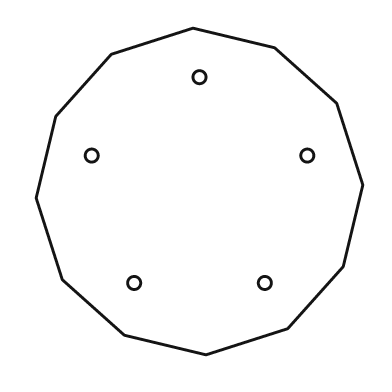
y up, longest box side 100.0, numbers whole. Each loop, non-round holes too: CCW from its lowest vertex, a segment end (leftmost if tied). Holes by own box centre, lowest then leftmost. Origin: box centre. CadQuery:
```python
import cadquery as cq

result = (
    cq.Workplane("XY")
    .moveTo(2.0, -50.0)
    .lineTo(27.0, -42.0)
    .lineTo(44.0, -23.0)
    .lineTo(50.0, 2.0)
    .lineTo(42.0, 27.0)
    .lineTo(23.0, 44.0)
    .lineTo(-2.0, 50.0)
    .lineTo(-27.0, 42.0)
    .lineTo(-44.0, 23.0)
    .lineTo(-50.0, -2.0)
    .lineTo(-42.0, -27.0)
    .lineTo(-23.0, -44.0)
    .close()
    .moveTo(-20.0, -28.0)
    .circle(2.0)
    .moveTo(20.0, -28.0)
    .circle(2.0)
    .moveTo(-33.0, 11.0)
    .circle(2.0)
    .moveTo(33.0, 11.0)
    .circle(2.0)
    .moveTo(0.0, 35.0)
    .circle(2.0)
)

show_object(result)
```